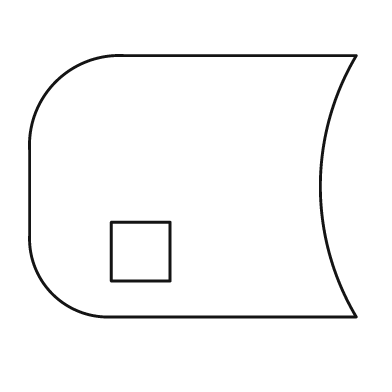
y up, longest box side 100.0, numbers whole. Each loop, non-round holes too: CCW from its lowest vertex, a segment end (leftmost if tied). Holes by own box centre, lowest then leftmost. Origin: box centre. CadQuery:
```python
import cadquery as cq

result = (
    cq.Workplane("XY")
    .moveTo(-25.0, -40.0)
    .lineTo(50.0, -40.0)
    .threePointArc((39.0, 0.0), (50.0, 40.0))
    .lineTo(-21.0, 40.0)
    .threePointArc((-42.0, 32.0), (-50.0, 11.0))
    .lineTo(-50.0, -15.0)
    .threePointArc((-43.0, -33.0), (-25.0, -40.0))
    .close()
    .moveTo(-25.0, -29.0)
    .lineTo(-7.0, -29.0)
    .lineTo(-7.0, -11.0)
    .lineTo(-25.0, -11.0)
    .close()
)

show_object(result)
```